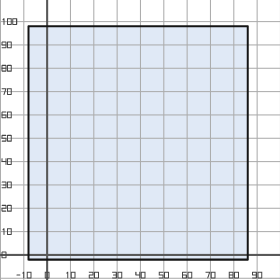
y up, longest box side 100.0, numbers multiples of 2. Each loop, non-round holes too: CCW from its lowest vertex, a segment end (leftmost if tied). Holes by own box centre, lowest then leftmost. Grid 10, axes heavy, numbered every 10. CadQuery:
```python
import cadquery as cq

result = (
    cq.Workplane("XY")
    .moveTo(-8.0, -2.0)
    .lineTo(86.0, -2.0)
    .lineTo(86.0, 98.0)
    .lineTo(-8.0, 98.0)
    .close()
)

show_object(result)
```